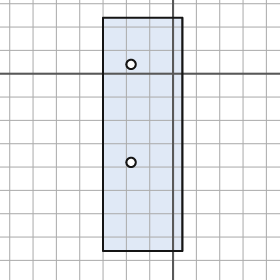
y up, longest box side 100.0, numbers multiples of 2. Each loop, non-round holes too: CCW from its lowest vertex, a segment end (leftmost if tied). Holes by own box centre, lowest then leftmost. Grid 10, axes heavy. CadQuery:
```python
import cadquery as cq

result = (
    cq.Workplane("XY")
    .moveTo(-30.0, -76.0)
    .lineTo(4.0, -76.0)
    .lineTo(4.0, 24.0)
    .lineTo(-30.0, 24.0)
    .close()
    .moveTo(-18.0, -38.0)
    .circle(2.0)
    .moveTo(-18.0, 4.0)
    .circle(2.0)
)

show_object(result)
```